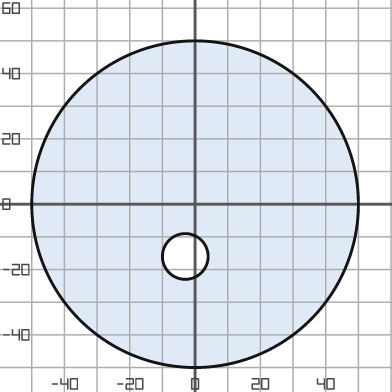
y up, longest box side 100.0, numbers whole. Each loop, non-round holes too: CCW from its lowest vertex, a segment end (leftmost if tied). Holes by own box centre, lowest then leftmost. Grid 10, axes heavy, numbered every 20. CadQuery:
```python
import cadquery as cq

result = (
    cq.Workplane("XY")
    .moveTo(0.0, 0.0)
    .circle(50.0)
    .moveTo(-3.0, -16.0)
    .circle(7.0)
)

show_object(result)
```